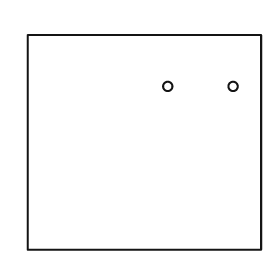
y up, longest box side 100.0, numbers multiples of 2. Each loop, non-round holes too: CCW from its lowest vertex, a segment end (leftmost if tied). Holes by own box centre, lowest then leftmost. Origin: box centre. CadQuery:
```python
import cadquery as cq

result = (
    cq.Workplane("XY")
    .moveTo(-50.0, -46.0)
    .lineTo(50.0, -46.0)
    .lineTo(50.0, 46.0)
    .lineTo(-50.0, 46.0)
    .close()
    .moveTo(10.0, 24.0)
    .circle(2.0)
    .moveTo(38.0, 24.0)
    .circle(2.0)
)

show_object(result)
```